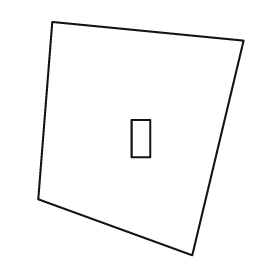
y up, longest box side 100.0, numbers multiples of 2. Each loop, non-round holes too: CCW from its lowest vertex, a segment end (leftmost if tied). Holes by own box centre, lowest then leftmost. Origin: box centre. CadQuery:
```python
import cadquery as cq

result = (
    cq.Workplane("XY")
    .moveTo(22.0, -50.0)
    .lineTo(44.0, 42.0)
    .lineTo(-38.0, 50.0)
    .lineTo(-44.0, -26.0)
    .close()
    .moveTo(-4.0, -8.0)
    .lineTo(4.0, -8.0)
    .lineTo(4.0, 8.0)
    .lineTo(-4.0, 8.0)
    .close()
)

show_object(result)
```